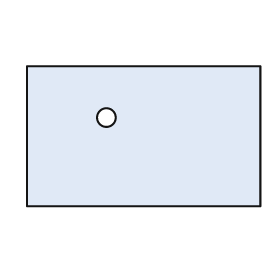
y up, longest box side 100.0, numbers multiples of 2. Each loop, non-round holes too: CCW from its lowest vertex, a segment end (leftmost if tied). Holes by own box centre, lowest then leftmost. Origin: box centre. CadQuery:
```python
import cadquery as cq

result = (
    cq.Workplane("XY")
    .moveTo(-50.0, -30.0)
    .lineTo(50.0, -30.0)
    .lineTo(50.0, 30.0)
    .lineTo(-50.0, 30.0)
    .close()
    .moveTo(-16.0, 8.0)
    .circle(4.0)
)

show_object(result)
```